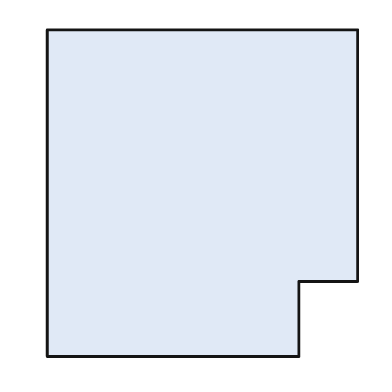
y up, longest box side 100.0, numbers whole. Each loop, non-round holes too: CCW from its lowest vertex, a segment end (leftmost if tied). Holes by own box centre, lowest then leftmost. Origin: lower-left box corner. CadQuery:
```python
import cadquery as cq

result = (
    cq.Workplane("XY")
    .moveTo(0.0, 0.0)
    .lineTo(77.0, 0.0)
    .lineTo(77.0, 23.0)
    .lineTo(95.0, 23.0)
    .lineTo(95.0, 100.0)
    .lineTo(0.0, 100.0)
    .close()
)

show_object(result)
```